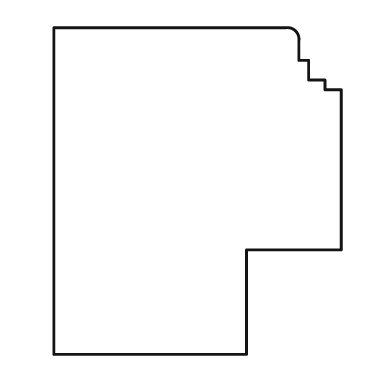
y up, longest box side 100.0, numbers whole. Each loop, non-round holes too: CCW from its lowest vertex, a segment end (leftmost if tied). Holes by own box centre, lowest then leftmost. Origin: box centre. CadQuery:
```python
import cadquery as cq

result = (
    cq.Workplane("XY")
    .moveTo(-44.0, -50.0)
    .lineTo(15.0, -50.0)
    .lineTo(15.0, -18.0)
    .lineTo(44.0, -18.0)
    .lineTo(44.0, 31.0)
    .lineTo(39.0, 31.0)
    .lineTo(39.0, 34.0)
    .lineTo(34.0, 34.0)
    .lineTo(34.0, 40.0)
    .lineTo(31.0, 40.0)
    .lineTo(31.0, 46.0)
    .threePointArc((30.0, 49.0), (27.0, 50.0))
    .lineTo(-44.0, 50.0)
    .close()
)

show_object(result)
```